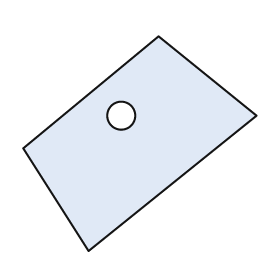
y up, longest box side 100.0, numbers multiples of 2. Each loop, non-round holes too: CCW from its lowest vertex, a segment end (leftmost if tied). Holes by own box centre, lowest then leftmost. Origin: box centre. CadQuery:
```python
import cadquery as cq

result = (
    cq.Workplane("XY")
    .moveTo(-22.0, -46.0)
    .lineTo(50.0, 12.0)
    .lineTo(8.0, 46.0)
    .lineTo(-50.0, -2.0)
    .close()
    .moveTo(-8.0, 12.0)
    .circle(6.0)
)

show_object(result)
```